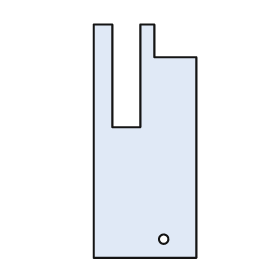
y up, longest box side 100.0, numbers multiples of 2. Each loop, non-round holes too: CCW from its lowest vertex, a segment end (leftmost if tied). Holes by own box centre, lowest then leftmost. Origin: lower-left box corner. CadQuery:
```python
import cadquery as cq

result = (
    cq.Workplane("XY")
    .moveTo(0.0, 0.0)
    .lineTo(44.0, 0.0)
    .lineTo(44.0, 86.0)
    .lineTo(26.0, 86.0)
    .lineTo(26.0, 100.0)
    .lineTo(20.0, 100.0)
    .lineTo(20.0, 56.0)
    .lineTo(8.0, 56.0)
    .lineTo(8.0, 100.0)
    .lineTo(0.0, 100.0)
    .close()
    .moveTo(30.0, 8.0)
    .circle(2.0)
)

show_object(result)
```